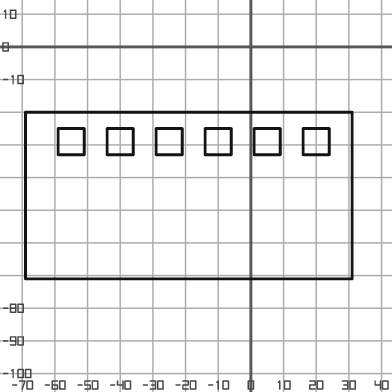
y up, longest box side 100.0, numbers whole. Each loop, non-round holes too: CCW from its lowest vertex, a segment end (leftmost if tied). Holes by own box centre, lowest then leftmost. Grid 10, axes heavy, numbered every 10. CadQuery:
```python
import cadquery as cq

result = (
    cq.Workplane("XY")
    .moveTo(-69.0, -71.0)
    .lineTo(31.0, -71.0)
    .lineTo(31.0, -20.0)
    .lineTo(-69.0, -20.0)
    .close()
    .moveTo(-59.0, -33.0)
    .lineTo(-51.0, -33.0)
    .lineTo(-51.0, -25.0)
    .lineTo(-59.0, -25.0)
    .close()
    .moveTo(-44.0, -33.0)
    .lineTo(-36.0, -33.0)
    .lineTo(-36.0, -25.0)
    .lineTo(-44.0, -25.0)
    .close()
    .moveTo(-29.0, -33.0)
    .lineTo(-21.0, -33.0)
    .lineTo(-21.0, -25.0)
    .lineTo(-29.0, -25.0)
    .close()
    .moveTo(-14.0, -33.0)
    .lineTo(-6.0, -33.0)
    .lineTo(-6.0, -25.0)
    .lineTo(-14.0, -25.0)
    .close()
    .moveTo(1.0, -33.0)
    .lineTo(9.0, -33.0)
    .lineTo(9.0, -25.0)
    .lineTo(1.0, -25.0)
    .close()
    .moveTo(16.0, -33.0)
    .lineTo(24.0, -33.0)
    .lineTo(24.0, -25.0)
    .lineTo(16.0, -25.0)
    .close()
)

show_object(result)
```